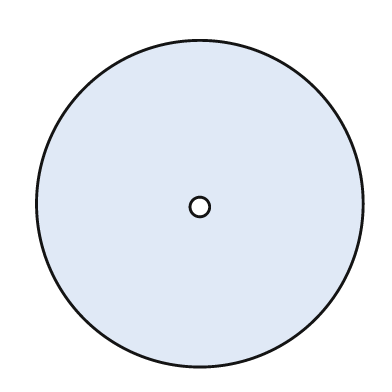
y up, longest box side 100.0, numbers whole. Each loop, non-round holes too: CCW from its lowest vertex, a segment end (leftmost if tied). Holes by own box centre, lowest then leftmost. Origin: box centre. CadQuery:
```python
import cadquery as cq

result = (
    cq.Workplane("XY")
    .moveTo(0.0, 0.0)
    .circle(50.0)
    .moveTo(0.0, -1.0)
    .circle(3.0)
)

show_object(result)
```